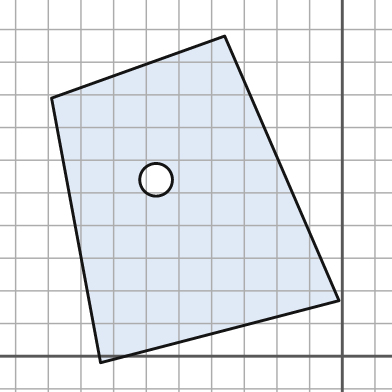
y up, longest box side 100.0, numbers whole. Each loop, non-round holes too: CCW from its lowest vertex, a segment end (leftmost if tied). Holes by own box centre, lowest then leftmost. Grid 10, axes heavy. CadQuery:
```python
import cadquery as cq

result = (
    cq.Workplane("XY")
    .moveTo(-74.0, -2.0)
    .lineTo(-1.0, 17.0)
    .lineTo(-36.0, 98.0)
    .lineTo(-89.0, 79.0)
    .close()
    .moveTo(-57.0, 54.0)
    .circle(5.0)
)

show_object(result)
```